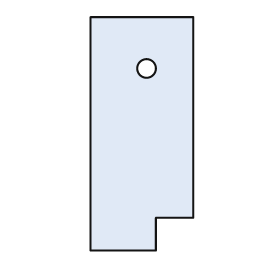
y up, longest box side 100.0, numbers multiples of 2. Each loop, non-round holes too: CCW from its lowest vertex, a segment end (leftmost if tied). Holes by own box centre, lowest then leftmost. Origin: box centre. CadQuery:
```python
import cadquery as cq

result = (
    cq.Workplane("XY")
    .moveTo(-22.0, -50.0)
    .lineTo(6.0, -50.0)
    .lineTo(6.0, -36.0)
    .lineTo(22.0, -36.0)
    .lineTo(22.0, 50.0)
    .lineTo(-22.0, 50.0)
    .close()
    .moveTo(2.0, 28.0)
    .circle(4.0)
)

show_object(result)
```